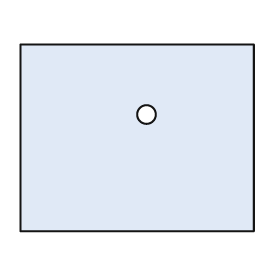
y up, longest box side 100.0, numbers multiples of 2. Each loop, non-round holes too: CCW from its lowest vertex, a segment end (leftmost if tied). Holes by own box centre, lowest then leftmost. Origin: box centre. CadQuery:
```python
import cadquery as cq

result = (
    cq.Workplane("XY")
    .moveTo(-50.0, -40.0)
    .lineTo(50.0, -40.0)
    .lineTo(50.0, 40.0)
    .lineTo(-50.0, 40.0)
    .close()
    .moveTo(4.0, 10.0)
    .circle(4.0)
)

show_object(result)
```